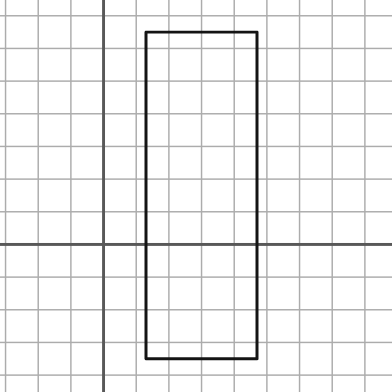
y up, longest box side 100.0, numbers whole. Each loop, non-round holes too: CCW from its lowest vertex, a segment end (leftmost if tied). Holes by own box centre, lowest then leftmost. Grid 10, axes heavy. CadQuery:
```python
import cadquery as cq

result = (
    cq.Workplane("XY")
    .moveTo(13.0, -35.0)
    .lineTo(47.0, -35.0)
    .lineTo(47.0, 65.0)
    .lineTo(13.0, 65.0)
    .close()
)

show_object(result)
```